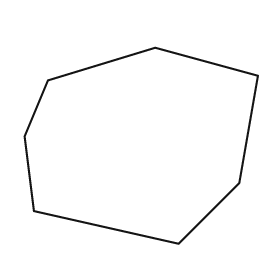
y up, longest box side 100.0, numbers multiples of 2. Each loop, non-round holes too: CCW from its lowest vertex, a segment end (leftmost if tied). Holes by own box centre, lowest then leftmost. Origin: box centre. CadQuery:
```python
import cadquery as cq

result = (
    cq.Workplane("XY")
    .moveTo(16.0, -42.0)
    .lineTo(42.0, -16.0)
    .lineTo(50.0, 30.0)
    .lineTo(6.0, 42.0)
    .lineTo(-40.0, 28.0)
    .lineTo(-50.0, 4.0)
    .lineTo(-46.0, -28.0)
    .close()
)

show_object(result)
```